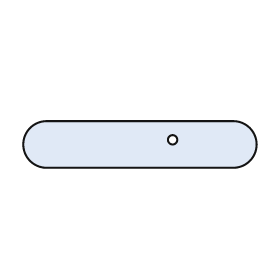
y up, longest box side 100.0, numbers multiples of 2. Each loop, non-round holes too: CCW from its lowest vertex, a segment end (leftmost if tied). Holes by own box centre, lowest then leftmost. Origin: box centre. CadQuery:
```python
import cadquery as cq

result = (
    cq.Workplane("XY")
    .moveTo(-40.0, -10.0)
    .lineTo(40.0, -10.0)
    .threePointArc((50.0, 0.0), (40.0, 10.0))
    .lineTo(-40.0, 10.0)
    .threePointArc((-50.0, 0.0), (-40.0, -10.0))
    .close()
    .moveTo(14.0, 2.0)
    .circle(2.0)
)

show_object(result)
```